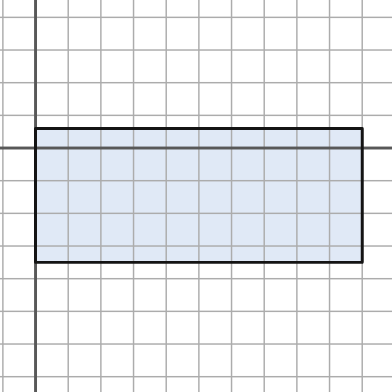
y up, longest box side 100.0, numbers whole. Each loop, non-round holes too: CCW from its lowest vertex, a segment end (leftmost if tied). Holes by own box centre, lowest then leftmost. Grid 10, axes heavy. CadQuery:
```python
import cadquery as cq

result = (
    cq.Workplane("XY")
    .moveTo(0.0, -35.0)
    .lineTo(100.0, -35.0)
    .lineTo(100.0, 6.0)
    .lineTo(0.0, 6.0)
    .close()
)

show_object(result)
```